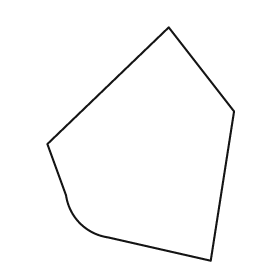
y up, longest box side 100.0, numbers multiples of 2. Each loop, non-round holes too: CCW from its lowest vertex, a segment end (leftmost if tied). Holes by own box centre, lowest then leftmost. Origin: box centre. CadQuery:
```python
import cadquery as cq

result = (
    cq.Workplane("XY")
    .moveTo(30.0, -50.0)
    .lineTo(40.0, 14.0)
    .lineTo(12.0, 50.0)
    .lineTo(-40.0, 0.0)
    .lineTo(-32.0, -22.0)
    .threePointArc((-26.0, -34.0), (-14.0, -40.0))
    .close()
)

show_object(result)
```